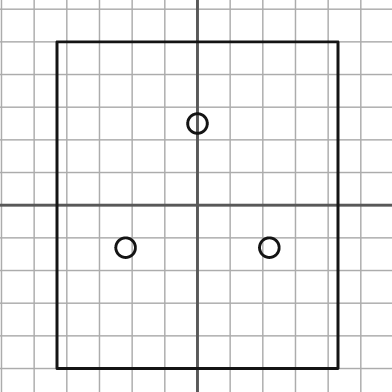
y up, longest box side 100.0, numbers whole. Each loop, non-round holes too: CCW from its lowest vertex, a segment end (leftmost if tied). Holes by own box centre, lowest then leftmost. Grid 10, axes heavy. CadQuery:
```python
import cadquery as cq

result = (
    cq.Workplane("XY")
    .moveTo(-43.0, -50.0)
    .lineTo(43.0, -50.0)
    .lineTo(43.0, 50.0)
    .lineTo(-43.0, 50.0)
    .close()
    .moveTo(-22.0, -13.0)
    .circle(3.0)
    .moveTo(22.0, -13.0)
    .circle(3.0)
    .moveTo(0.0, 25.0)
    .circle(3.0)
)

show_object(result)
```